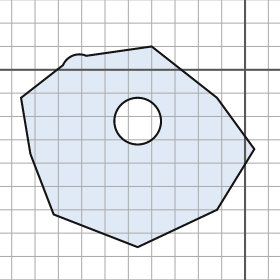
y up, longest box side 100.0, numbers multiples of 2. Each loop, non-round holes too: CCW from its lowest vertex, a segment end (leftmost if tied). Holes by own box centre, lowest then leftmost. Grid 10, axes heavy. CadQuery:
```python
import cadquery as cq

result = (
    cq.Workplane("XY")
    .moveTo(-46.0, -76.0)
    .lineTo(-12.0, -60.0)
    .lineTo(4.0, -34.0)
    .lineTo(-12.0, -12.0)
    .lineTo(-40.0, 10.0)
    .lineTo(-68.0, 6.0)
    .threePointArc((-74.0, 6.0), (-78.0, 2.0))
    .lineTo(-96.0, -12.0)
    .lineTo(-92.0, -36.0)
    .lineTo(-82.0, -62.0)
    .close()
    .moveTo(-46.0, -22.0)
    .circle(10.0)
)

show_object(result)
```